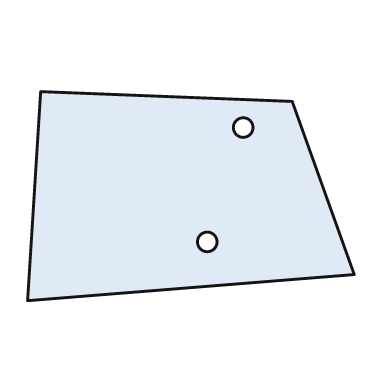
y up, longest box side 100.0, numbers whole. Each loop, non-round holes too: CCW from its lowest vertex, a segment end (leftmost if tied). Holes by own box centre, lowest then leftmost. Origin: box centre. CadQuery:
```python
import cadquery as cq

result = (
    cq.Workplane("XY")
    .moveTo(-50.0, -32.0)
    .lineTo(50.0, -24.0)
    .lineTo(31.0, 29.0)
    .lineTo(-46.0, 32.0)
    .close()
    .moveTo(5.0, -14.0)
    .circle(3.0)
    .moveTo(16.0, 21.0)
    .circle(3.0)
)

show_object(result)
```